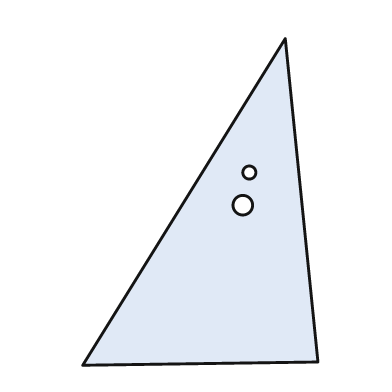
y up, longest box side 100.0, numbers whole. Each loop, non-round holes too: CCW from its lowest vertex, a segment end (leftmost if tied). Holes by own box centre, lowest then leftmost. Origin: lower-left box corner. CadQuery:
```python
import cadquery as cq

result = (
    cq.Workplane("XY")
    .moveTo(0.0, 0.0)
    .lineTo(72.0, 1.0)
    .lineTo(62.0, 100.0)
    .close()
    .moveTo(49.0, 49.0)
    .circle(3.0)
    .moveTo(51.0, 59.0)
    .circle(2.0)
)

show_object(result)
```